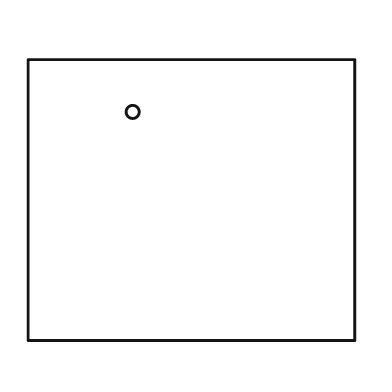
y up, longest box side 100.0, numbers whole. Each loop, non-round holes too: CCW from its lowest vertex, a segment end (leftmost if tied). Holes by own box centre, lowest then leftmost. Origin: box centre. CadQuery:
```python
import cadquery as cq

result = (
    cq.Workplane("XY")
    .moveTo(-50.0, -43.0)
    .lineTo(50.0, -43.0)
    .lineTo(50.0, 43.0)
    .lineTo(-50.0, 43.0)
    .close()
    .moveTo(-18.0, 27.0)
    .circle(2.0)
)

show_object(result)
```